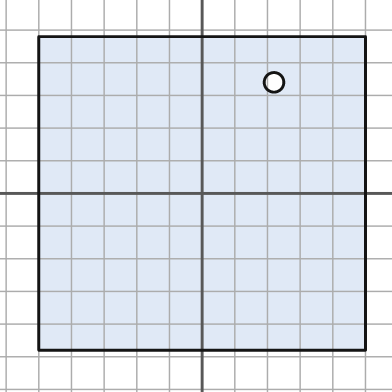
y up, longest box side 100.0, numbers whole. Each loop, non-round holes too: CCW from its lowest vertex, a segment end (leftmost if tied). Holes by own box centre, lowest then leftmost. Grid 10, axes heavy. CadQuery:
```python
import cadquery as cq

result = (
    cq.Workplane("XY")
    .moveTo(-50.0, -48.0)
    .lineTo(50.0, -48.0)
    .lineTo(50.0, 48.0)
    .lineTo(-50.0, 48.0)
    .close()
    .moveTo(22.0, 34.0)
    .circle(3.0)
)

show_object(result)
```